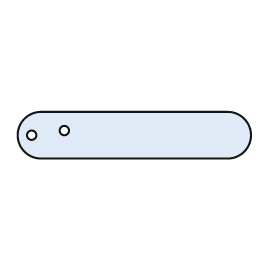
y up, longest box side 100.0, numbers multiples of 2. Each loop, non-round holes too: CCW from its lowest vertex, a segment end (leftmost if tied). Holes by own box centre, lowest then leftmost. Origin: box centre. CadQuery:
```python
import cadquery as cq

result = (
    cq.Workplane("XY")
    .moveTo(-40.0, -10.0)
    .lineTo(40.0, -10.0)
    .threePointArc((50.0, 0.0), (40.0, 10.0))
    .lineTo(-40.0, 10.0)
    .threePointArc((-50.0, 0.0), (-40.0, -10.0))
    .close()
    .moveTo(-44.0, 0.0)
    .circle(2.0)
    .moveTo(-30.0, 2.0)
    .circle(2.0)
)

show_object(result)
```